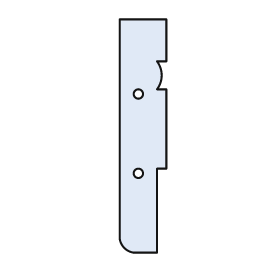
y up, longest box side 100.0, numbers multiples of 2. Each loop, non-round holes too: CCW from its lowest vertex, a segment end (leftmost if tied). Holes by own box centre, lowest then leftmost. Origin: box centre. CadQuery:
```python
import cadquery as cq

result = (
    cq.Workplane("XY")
    .moveTo(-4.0, -50.0)
    .lineTo(6.0, -50.0)
    .lineTo(6.0, -14.0)
    .lineTo(10.0, -14.0)
    .lineTo(10.0, 20.0)
    .lineTo(6.0, 20.0)
    .threePointArc((8.0, 26.0), (6.0, 32.0))
    .lineTo(10.0, 32.0)
    .lineTo(10.0, 50.0)
    .lineTo(-10.0, 50.0)
    .lineTo(-10.0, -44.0)
    .threePointArc((-8.0, -48.0), (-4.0, -50.0))
    .close()
    .moveTo(-2.0, -16.0)
    .circle(2.0)
    .moveTo(-2.0, 18.0)
    .circle(2.0)
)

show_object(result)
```